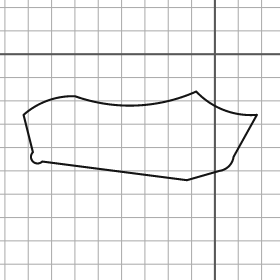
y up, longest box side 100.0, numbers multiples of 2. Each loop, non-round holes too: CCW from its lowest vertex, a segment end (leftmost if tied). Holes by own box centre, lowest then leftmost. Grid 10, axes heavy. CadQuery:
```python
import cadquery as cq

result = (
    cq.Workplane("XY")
    .moveTo(-12.0, -54.0)
    .lineTo(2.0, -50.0)
    .threePointArc((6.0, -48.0), (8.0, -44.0))
    .lineTo(18.0, -26.0)
    .threePointArc((4.0, -24.0), (-8.0, -16.0))
    .threePointArc((-34.0, -22.0), (-60.0, -18.0))
    .threePointArc((-72.0, -20.0), (-82.0, -26.0))
    .lineTo(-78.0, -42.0)
    .threePointArc((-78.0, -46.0), (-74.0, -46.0))
    .close()
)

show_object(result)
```